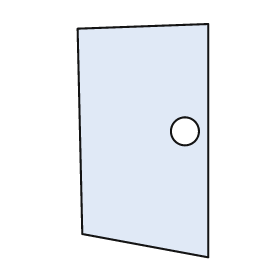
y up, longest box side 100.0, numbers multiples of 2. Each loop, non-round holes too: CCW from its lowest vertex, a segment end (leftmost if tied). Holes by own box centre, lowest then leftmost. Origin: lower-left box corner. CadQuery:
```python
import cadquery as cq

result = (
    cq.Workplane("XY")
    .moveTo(56.0, 0.0)
    .lineTo(56.0, 100.0)
    .lineTo(0.0, 98.0)
    .lineTo(2.0, 10.0)
    .close()
    .moveTo(46.0, 54.0)
    .circle(6.0)
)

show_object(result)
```